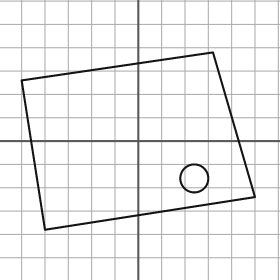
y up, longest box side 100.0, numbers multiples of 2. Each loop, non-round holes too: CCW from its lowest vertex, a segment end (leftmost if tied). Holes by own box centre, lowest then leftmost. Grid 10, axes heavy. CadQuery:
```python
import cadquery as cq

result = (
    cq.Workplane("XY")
    .moveTo(-40.0, -38.0)
    .lineTo(50.0, -24.0)
    .lineTo(32.0, 38.0)
    .lineTo(-50.0, 26.0)
    .close()
    .moveTo(24.0, -16.0)
    .circle(6.0)
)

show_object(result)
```